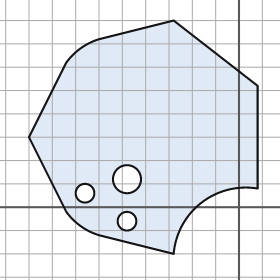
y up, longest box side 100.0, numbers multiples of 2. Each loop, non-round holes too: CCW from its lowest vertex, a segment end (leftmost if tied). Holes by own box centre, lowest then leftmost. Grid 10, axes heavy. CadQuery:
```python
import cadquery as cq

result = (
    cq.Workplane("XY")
    .moveTo(-28.0, -20.0)
    .threePointArc((-16.0, 2.0), (8.0, 8.0))
    .lineTo(8.0, 52.0)
    .lineTo(-28.0, 80.0)
    .lineTo(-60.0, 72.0)
    .threePointArc((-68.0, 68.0), (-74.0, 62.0))
    .lineTo(-90.0, 30.0)
    .lineTo(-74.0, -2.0)
    .threePointArc((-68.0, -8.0), (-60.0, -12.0))
    .close()
    .moveTo(-48.0, -6.0)
    .circle(4.0)
    .moveTo(-66.0, 6.0)
    .circle(4.0)
    .moveTo(-48.0, 12.0)
    .circle(6.0)
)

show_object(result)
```